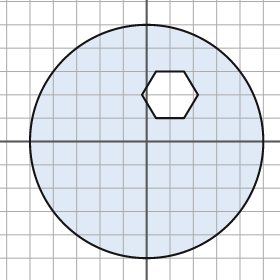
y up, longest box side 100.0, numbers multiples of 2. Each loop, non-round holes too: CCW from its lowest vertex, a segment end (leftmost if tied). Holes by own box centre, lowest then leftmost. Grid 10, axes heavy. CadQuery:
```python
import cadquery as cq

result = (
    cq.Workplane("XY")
    .moveTo(0.0, 0.0)
    .circle(50.0)
    .moveTo(4.0, 10.0)
    .lineTo(16.0, 10.0)
    .lineTo(22.0, 20.0)
    .lineTo(16.0, 30.0)
    .lineTo(4.0, 30.0)
    .lineTo(-2.0, 20.0)
    .close()
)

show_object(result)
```